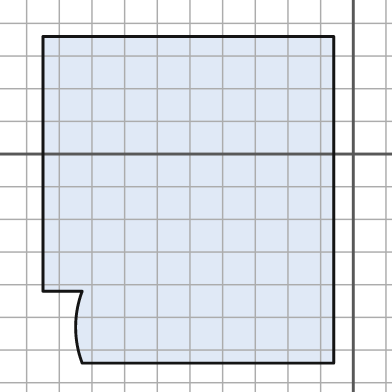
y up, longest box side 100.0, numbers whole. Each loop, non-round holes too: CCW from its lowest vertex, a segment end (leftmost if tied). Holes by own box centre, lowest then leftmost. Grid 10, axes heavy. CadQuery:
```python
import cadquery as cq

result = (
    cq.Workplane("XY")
    .moveTo(-83.0, -64.0)
    .lineTo(-6.0, -64.0)
    .lineTo(-6.0, 36.0)
    .lineTo(-95.0, 36.0)
    .lineTo(-95.0, -42.0)
    .lineTo(-83.0, -42.0)
    .threePointArc((-85.0, -53.0), (-83.0, -64.0))
    .close()
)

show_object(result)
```